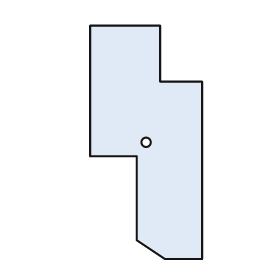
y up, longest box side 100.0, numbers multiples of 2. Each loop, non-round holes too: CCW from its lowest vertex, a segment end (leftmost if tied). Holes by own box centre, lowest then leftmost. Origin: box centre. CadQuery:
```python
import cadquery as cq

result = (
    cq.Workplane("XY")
    .moveTo(8.0, -50.0)
    .lineTo(24.0, -50.0)
    .lineTo(24.0, 26.0)
    .lineTo(6.0, 26.0)
    .lineTo(6.0, 50.0)
    .lineTo(-24.0, 50.0)
    .lineTo(-24.0, -6.0)
    .lineTo(-4.0, -6.0)
    .lineTo(-4.0, -42.0)
    .close()
    .moveTo(0.0, 0.0)
    .circle(2.0)
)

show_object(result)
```